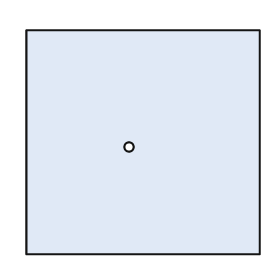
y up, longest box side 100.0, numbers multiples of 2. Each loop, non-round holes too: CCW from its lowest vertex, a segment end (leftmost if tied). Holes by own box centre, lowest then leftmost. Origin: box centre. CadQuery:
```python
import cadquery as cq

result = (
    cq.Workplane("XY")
    .moveTo(-50.0, -48.0)
    .lineTo(50.0, -48.0)
    .lineTo(50.0, 48.0)
    .lineTo(-50.0, 48.0)
    .close()
    .moveTo(-6.0, -2.0)
    .circle(2.0)
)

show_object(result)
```